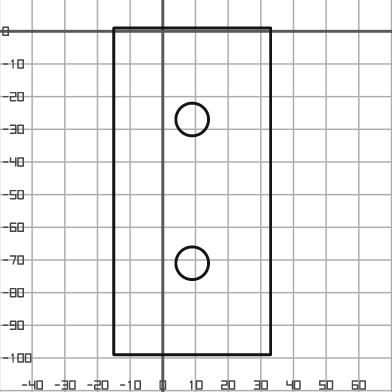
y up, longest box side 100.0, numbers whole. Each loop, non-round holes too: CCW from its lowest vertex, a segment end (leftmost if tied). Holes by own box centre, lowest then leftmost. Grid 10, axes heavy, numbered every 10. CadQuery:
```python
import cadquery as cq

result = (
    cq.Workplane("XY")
    .moveTo(-15.0, -99.0)
    .lineTo(33.0, -99.0)
    .lineTo(33.0, 1.0)
    .lineTo(-15.0, 1.0)
    .close()
    .moveTo(9.0, -71.0)
    .circle(5.0)
    .moveTo(9.0, -27.0)
    .circle(5.0)
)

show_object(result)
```